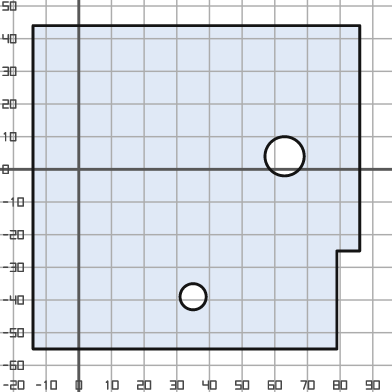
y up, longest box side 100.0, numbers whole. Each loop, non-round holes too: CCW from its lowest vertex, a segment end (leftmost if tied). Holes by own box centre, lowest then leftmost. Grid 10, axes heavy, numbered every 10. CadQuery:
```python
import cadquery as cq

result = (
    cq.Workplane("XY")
    .moveTo(-14.0, -55.0)
    .lineTo(79.0, -55.0)
    .lineTo(79.0, -25.0)
    .lineTo(86.0, -25.0)
    .lineTo(86.0, 44.0)
    .lineTo(-14.0, 44.0)
    .close()
    .moveTo(35.0, -39.0)
    .circle(4.0)
    .moveTo(63.0, 4.0)
    .circle(6.0)
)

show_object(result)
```